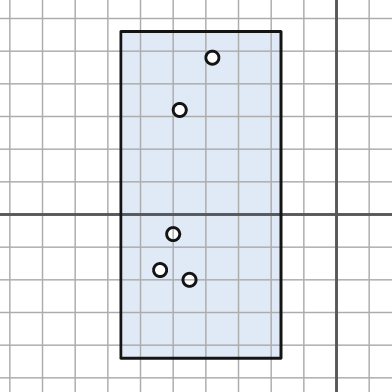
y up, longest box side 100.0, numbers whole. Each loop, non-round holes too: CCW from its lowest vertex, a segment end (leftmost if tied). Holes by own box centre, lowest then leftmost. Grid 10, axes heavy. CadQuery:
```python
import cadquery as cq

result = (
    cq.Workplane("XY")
    .moveTo(-66.0, -44.0)
    .lineTo(-17.0, -44.0)
    .lineTo(-17.0, 56.0)
    .lineTo(-66.0, 56.0)
    .close()
    .moveTo(-45.0, -20.0)
    .circle(2.0)
    .moveTo(-54.0, -17.0)
    .circle(2.0)
    .moveTo(-50.0, -6.0)
    .circle(2.0)
    .moveTo(-48.0, 32.0)
    .circle(2.0)
    .moveTo(-38.0, 48.0)
    .circle(2.0)
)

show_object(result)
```